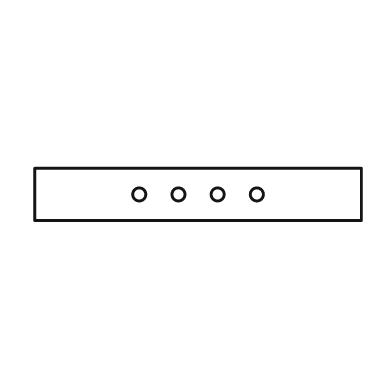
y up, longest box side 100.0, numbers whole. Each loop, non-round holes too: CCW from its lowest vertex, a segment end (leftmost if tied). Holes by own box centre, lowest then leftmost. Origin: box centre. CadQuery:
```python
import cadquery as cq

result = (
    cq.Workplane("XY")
    .moveTo(-50.0, -8.0)
    .lineTo(50.0, -8.0)
    .lineTo(50.0, 8.0)
    .lineTo(-50.0, 8.0)
    .close()
    .moveTo(-18.0, 0.0)
    .circle(2.0)
    .moveTo(-6.0, 0.0)
    .circle(2.0)
    .moveTo(6.0, 0.0)
    .circle(2.0)
    .moveTo(18.0, 0.0)
    .circle(2.0)
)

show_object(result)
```